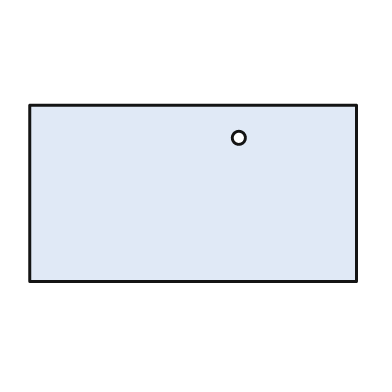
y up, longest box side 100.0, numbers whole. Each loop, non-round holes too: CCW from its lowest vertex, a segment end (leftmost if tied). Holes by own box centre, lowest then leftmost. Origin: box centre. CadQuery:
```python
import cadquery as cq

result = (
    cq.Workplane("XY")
    .moveTo(-50.0, -27.0)
    .lineTo(50.0, -27.0)
    .lineTo(50.0, 27.0)
    .lineTo(-50.0, 27.0)
    .close()
    .moveTo(14.0, 17.0)
    .circle(2.0)
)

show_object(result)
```